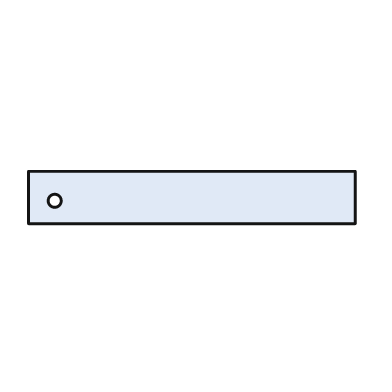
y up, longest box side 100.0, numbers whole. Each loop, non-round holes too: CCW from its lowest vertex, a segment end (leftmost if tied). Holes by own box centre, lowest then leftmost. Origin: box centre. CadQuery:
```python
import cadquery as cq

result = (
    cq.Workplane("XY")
    .moveTo(-50.0, -8.0)
    .lineTo(50.0, -8.0)
    .lineTo(50.0, 8.0)
    .lineTo(-50.0, 8.0)
    .close()
    .moveTo(-42.0, -1.0)
    .circle(2.0)
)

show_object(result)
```